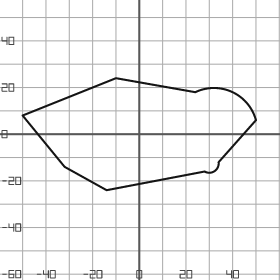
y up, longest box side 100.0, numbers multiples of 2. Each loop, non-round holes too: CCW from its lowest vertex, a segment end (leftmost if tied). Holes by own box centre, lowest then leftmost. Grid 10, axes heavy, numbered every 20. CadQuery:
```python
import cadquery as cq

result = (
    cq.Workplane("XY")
    .moveTo(-14.0, -24.0)
    .lineTo(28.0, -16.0)
    .threePointArc((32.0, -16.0), (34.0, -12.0))
    .lineTo(50.0, 6.0)
    .threePointArc((40.0, 18.0), (24.0, 18.0))
    .lineTo(-10.0, 24.0)
    .lineTo(-50.0, 8.0)
    .lineTo(-32.0, -14.0)
    .close()
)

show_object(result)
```